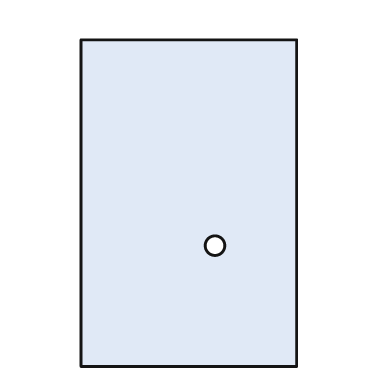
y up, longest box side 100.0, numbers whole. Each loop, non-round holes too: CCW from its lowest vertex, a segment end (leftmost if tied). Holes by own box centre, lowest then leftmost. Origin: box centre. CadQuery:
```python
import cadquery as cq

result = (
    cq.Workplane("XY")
    .moveTo(-33.0, -50.0)
    .lineTo(33.0, -50.0)
    .lineTo(33.0, 50.0)
    .lineTo(-33.0, 50.0)
    .close()
    .moveTo(8.0, -13.0)
    .circle(3.0)
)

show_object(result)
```